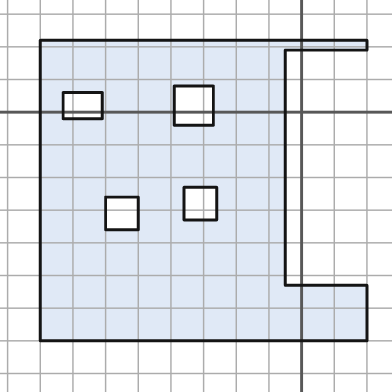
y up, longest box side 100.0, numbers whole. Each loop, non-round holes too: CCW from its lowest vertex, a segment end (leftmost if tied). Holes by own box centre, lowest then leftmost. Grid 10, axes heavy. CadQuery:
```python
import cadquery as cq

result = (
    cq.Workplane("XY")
    .moveTo(-80.0, -70.0)
    .lineTo(20.0, -70.0)
    .lineTo(20.0, -53.0)
    .lineTo(-5.0, -53.0)
    .lineTo(-5.0, 19.0)
    .lineTo(20.0, 19.0)
    .lineTo(20.0, 22.0)
    .lineTo(-80.0, 22.0)
    .close()
    .moveTo(-60.0, -36.0)
    .lineTo(-50.0, -36.0)
    .lineTo(-50.0, -26.0)
    .lineTo(-60.0, -26.0)
    .close()
    .moveTo(-36.0, -33.0)
    .lineTo(-26.0, -33.0)
    .lineTo(-26.0, -23.0)
    .lineTo(-36.0, -23.0)
    .close()
    .moveTo(-73.0, -2.0)
    .lineTo(-61.0, -2.0)
    .lineTo(-61.0, 6.0)
    .lineTo(-73.0, 6.0)
    .close()
    .moveTo(-39.0, -4.0)
    .lineTo(-27.0, -4.0)
    .lineTo(-27.0, 8.0)
    .lineTo(-39.0, 8.0)
    .close()
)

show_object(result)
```